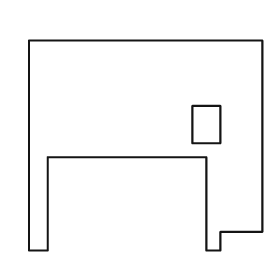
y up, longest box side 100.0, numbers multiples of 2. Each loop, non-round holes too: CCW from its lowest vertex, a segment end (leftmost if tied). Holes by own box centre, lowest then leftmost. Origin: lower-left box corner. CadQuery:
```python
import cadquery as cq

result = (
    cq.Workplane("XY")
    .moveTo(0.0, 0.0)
    .lineTo(8.0, 0.0)
    .lineTo(8.0, 40.0)
    .lineTo(76.0, 40.0)
    .lineTo(76.0, 0.0)
    .lineTo(82.0, 0.0)
    .lineTo(82.0, 8.0)
    .lineTo(100.0, 8.0)
    .lineTo(100.0, 90.0)
    .lineTo(0.0, 90.0)
    .close()
    .moveTo(70.0, 46.0)
    .lineTo(82.0, 46.0)
    .lineTo(82.0, 62.0)
    .lineTo(70.0, 62.0)
    .close()
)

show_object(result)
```